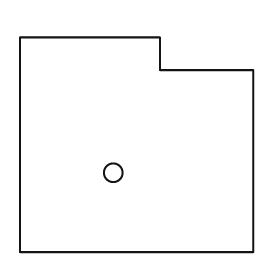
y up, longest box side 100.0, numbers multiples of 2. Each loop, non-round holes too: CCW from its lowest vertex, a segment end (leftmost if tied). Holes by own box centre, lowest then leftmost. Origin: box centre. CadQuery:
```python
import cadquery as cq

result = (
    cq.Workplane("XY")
    .moveTo(-50.0, -46.0)
    .lineTo(50.0, -46.0)
    .lineTo(50.0, 32.0)
    .lineTo(10.0, 32.0)
    .lineTo(10.0, 46.0)
    .lineTo(-50.0, 46.0)
    .close()
    .moveTo(-10.0, -12.0)
    .circle(4.0)
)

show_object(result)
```